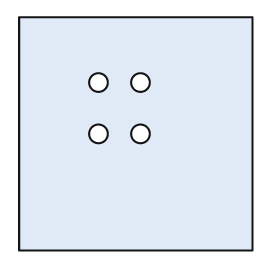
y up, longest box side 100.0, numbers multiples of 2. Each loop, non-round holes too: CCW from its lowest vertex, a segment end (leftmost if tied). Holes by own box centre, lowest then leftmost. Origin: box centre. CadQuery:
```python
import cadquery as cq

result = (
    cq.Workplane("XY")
    .moveTo(-50.0, -50.0)
    .lineTo(50.0, -50.0)
    .lineTo(50.0, 50.0)
    .lineTo(-50.0, 50.0)
    .close()
    .moveTo(-16.0, 0.0)
    .circle(4.0)
    .moveTo(2.0, 0.0)
    .circle(4.0)
    .moveTo(-16.0, 22.0)
    .circle(4.0)
    .moveTo(2.0, 22.0)
    .circle(4.0)
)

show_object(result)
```